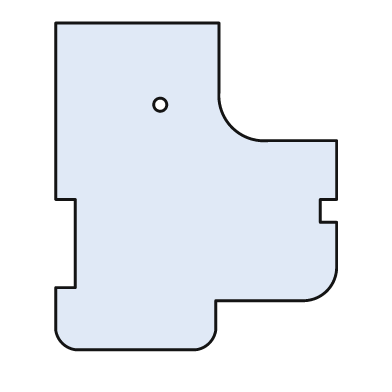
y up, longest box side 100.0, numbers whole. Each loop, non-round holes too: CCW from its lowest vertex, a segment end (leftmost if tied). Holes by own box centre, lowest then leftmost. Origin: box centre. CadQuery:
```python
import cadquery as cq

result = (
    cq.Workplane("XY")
    .moveTo(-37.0, -50.0)
    .lineTo(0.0, -50.0)
    .threePointArc((4.0, -48.0), (6.0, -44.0))
    .lineTo(6.0, -35.0)
    .lineTo(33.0, -35.0)
    .threePointArc((40.0, -32.0), (43.0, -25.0))
    .lineTo(43.0, -11.0)
    .lineTo(38.0, -11.0)
    .lineTo(38.0, -4.0)
    .lineTo(43.0, -4.0)
    .lineTo(43.0, 14.0)
    .lineTo(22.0, 14.0)
    .threePointArc((11.0, 18.0), (7.0, 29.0))
    .lineTo(7.0, 50.0)
    .lineTo(-43.0, 50.0)
    .lineTo(-43.0, -4.0)
    .lineTo(-37.0, -4.0)
    .lineTo(-37.0, -31.0)
    .lineTo(-43.0, -31.0)
    .lineTo(-43.0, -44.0)
    .threePointArc((-41.0, -48.0), (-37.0, -50.0))
    .close()
    .moveTo(-11.0, 25.0)
    .circle(2.0)
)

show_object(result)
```